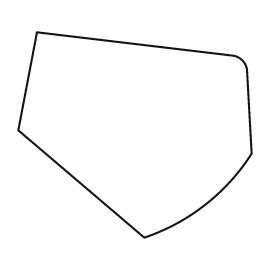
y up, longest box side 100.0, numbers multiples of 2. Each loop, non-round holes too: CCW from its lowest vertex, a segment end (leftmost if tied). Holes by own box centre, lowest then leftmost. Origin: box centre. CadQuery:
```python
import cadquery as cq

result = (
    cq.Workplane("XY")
    .moveTo(4.0, -44.0)
    .threePointArc((30.0, -30.0), (50.0, -8.0))
    .lineTo(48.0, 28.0)
    .threePointArc((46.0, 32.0), (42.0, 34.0))
    .lineTo(-42.0, 44.0)
    .lineTo(-50.0, 2.0)
    .close()
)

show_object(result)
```